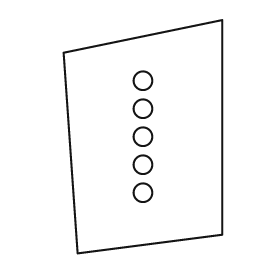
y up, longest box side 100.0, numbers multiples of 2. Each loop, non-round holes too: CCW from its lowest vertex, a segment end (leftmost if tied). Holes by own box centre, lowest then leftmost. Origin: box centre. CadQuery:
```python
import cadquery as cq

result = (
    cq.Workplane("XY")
    .moveTo(-28.0, -50.0)
    .lineTo(34.0, -42.0)
    .lineTo(34.0, 50.0)
    .lineTo(-34.0, 36.0)
    .close()
    .moveTo(0.0, -24.0)
    .circle(4.0)
    .moveTo(0.0, -12.0)
    .circle(4.0)
    .moveTo(0.0, 0.0)
    .circle(4.0)
    .moveTo(0.0, 12.0)
    .circle(4.0)
    .moveTo(0.0, 24.0)
    .circle(4.0)
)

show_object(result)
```